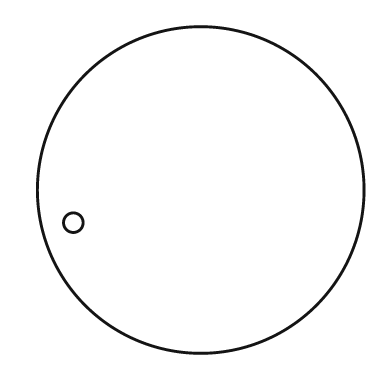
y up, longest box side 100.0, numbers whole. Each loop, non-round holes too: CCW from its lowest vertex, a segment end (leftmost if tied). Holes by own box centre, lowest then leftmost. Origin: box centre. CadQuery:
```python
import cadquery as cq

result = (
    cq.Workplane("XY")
    .moveTo(0.0, 0.0)
    .circle(50.0)
    .moveTo(-39.0, -10.0)
    .circle(3.0)
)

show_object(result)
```